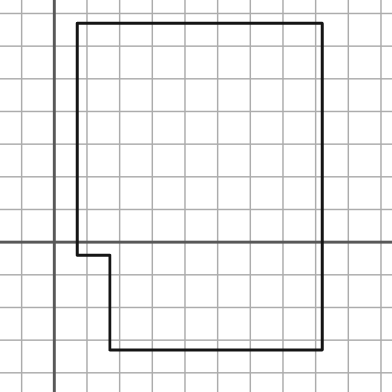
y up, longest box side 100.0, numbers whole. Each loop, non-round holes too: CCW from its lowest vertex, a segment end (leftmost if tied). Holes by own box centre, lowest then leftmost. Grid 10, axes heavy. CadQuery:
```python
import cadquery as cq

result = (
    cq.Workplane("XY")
    .moveTo(17.0, -33.0)
    .lineTo(82.0, -33.0)
    .lineTo(82.0, 67.0)
    .lineTo(7.0, 67.0)
    .lineTo(7.0, -4.0)
    .lineTo(17.0, -4.0)
    .close()
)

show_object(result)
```